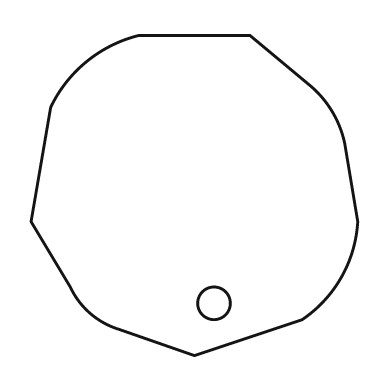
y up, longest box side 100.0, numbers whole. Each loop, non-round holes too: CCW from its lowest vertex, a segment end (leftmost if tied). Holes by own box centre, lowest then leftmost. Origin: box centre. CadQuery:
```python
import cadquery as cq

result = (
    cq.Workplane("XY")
    .moveTo(0.0, -49.0)
    .lineTo(33.0, -38.0)
    .threePointArc((45.0, -25.0), (50.0, -8.0))
    .lineTo(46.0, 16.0)
    .threePointArc((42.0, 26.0), (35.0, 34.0))
    .lineTo(17.0, 49.0)
    .lineTo(-17.0, 49.0)
    .threePointArc((-33.0, 41.0), (-44.0, 27.0))
    .lineTo(-50.0, -8.0)
    .lineTo(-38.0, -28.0)
    .threePointArc((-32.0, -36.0), (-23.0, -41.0))
    .close()
    .moveTo(6.0, -33.0)
    .circle(5.0)
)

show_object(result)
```